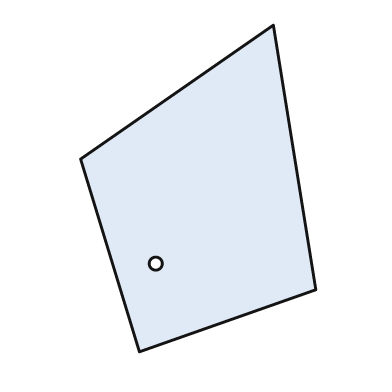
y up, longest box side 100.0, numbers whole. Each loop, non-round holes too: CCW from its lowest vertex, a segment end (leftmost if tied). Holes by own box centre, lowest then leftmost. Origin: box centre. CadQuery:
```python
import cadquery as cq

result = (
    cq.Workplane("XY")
    .moveTo(-18.0, -50.0)
    .lineTo(36.0, -31.0)
    .lineTo(23.0, 50.0)
    .lineTo(-36.0, 9.0)
    .close()
    .moveTo(-13.0, -23.0)
    .circle(2.0)
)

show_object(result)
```